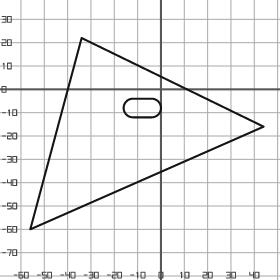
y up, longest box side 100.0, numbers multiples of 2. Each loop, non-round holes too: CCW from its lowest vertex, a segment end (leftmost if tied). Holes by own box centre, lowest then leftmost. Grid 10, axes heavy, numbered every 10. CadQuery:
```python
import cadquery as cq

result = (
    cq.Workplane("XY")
    .moveTo(-56.0, -60.0)
    .lineTo(44.0, -16.0)
    .lineTo(-34.0, 22.0)
    .close()
    .moveTo(-12.0, -12.0)
    .lineTo(-4.0, -12.0)
    .threePointArc((0.0, -8.0), (-4.0, -4.0))
    .lineTo(-12.0, -4.0)
    .threePointArc((-16.0, -8.0), (-12.0, -12.0))
    .close()
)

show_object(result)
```